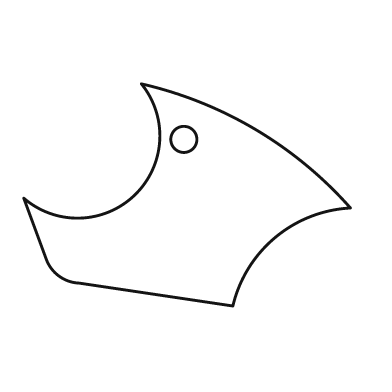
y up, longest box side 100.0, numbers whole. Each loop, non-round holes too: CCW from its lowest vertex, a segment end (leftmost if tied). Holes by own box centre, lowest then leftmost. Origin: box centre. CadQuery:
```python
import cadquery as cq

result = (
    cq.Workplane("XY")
    .moveTo(14.0, -34.0)
    .threePointArc((27.0, -13.0), (50.0, -4.0))
    .threePointArc((21.0, 20.0), (-14.0, 34.0))
    .threePointArc((-16.0, 0.0), (-50.0, -1.0))
    .lineTo(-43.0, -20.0)
    .threePointArc((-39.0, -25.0), (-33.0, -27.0))
    .close()
    .moveTo(-1.0, 17.0)
    .circle(4.0)
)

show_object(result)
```